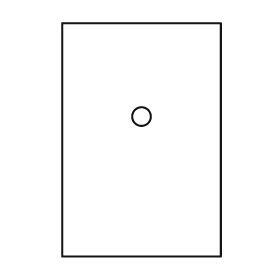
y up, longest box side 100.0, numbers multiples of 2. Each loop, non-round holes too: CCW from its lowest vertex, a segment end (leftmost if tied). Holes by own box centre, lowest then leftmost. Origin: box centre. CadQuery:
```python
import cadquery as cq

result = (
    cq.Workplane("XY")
    .moveTo(-34.0, -50.0)
    .lineTo(34.0, -50.0)
    .lineTo(34.0, 50.0)
    .lineTo(-34.0, 50.0)
    .close()
    .moveTo(0.0, 10.0)
    .circle(4.0)
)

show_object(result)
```